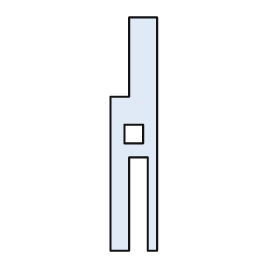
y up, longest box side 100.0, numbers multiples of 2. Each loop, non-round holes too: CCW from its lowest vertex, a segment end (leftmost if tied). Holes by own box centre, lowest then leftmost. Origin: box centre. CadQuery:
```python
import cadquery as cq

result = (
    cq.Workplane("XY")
    .moveTo(-10.0, -50.0)
    .lineTo(-2.0, -50.0)
    .lineTo(-2.0, -10.0)
    .lineTo(6.0, -10.0)
    .lineTo(6.0, -50.0)
    .lineTo(10.0, -50.0)
    .lineTo(10.0, 50.0)
    .lineTo(-2.0, 50.0)
    .lineTo(-2.0, 16.0)
    .lineTo(-10.0, 16.0)
    .close()
    .moveTo(-4.0, -4.0)
    .lineTo(4.0, -4.0)
    .lineTo(4.0, 4.0)
    .lineTo(-4.0, 4.0)
    .close()
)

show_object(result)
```